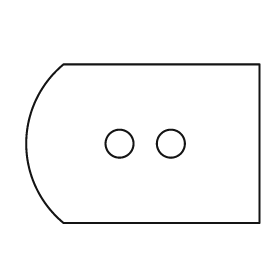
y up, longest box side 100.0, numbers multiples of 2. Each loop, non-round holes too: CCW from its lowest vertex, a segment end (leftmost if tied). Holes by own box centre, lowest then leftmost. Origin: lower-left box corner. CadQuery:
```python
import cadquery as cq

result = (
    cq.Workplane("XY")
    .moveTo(16.0, 0.0)
    .lineTo(100.0, 0.0)
    .lineTo(100.0, 68.0)
    .lineTo(16.0, 68.0)
    .threePointArc((0.0, 34.0), (16.0, 0.0))
    .close()
    .moveTo(40.0, 34.0)
    .circle(6.0)
    .moveTo(62.0, 34.0)
    .circle(6.0)
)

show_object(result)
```